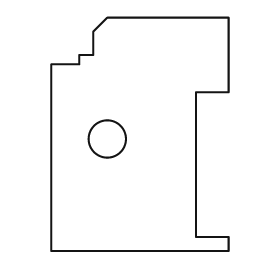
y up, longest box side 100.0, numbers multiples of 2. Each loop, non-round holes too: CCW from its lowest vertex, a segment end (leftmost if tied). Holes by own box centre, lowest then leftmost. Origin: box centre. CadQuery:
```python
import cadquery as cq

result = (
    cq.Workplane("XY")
    .moveTo(-38.0, -50.0)
    .lineTo(38.0, -50.0)
    .lineTo(38.0, -44.0)
    .lineTo(24.0, -44.0)
    .lineTo(24.0, 18.0)
    .lineTo(38.0, 18.0)
    .lineTo(38.0, 50.0)
    .lineTo(-14.0, 50.0)
    .lineTo(-20.0, 44.0)
    .lineTo(-20.0, 34.0)
    .lineTo(-26.0, 34.0)
    .lineTo(-26.0, 30.0)
    .lineTo(-38.0, 30.0)
    .close()
    .moveTo(-14.0, -2.0)
    .circle(8.0)
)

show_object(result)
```